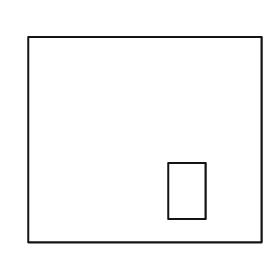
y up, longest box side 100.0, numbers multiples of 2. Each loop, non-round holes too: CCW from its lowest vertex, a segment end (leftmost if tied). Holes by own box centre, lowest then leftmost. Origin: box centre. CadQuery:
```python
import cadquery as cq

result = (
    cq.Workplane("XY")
    .moveTo(-50.0, -44.0)
    .lineTo(50.0, -44.0)
    .lineTo(50.0, 44.0)
    .lineTo(-50.0, 44.0)
    .close()
    .moveTo(10.0, -34.0)
    .lineTo(26.0, -34.0)
    .lineTo(26.0, -10.0)
    .lineTo(10.0, -10.0)
    .close()
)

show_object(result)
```